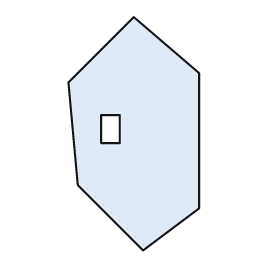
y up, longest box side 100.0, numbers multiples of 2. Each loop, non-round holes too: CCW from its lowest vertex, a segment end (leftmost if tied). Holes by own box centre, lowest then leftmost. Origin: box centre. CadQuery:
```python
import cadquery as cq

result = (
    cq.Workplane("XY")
    .moveTo(4.0, -50.0)
    .lineTo(28.0, -32.0)
    .lineTo(28.0, 26.0)
    .lineTo(0.0, 50.0)
    .lineTo(-28.0, 22.0)
    .lineTo(-24.0, -22.0)
    .close()
    .moveTo(-14.0, -4.0)
    .lineTo(-6.0, -4.0)
    .lineTo(-6.0, 8.0)
    .lineTo(-14.0, 8.0)
    .close()
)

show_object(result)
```